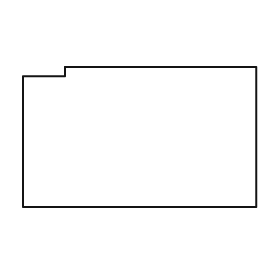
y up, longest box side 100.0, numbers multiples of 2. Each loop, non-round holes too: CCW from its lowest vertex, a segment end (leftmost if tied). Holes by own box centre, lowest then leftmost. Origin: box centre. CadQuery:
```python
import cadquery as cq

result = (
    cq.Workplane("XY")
    .moveTo(-50.0, -30.0)
    .lineTo(50.0, -30.0)
    .lineTo(50.0, 30.0)
    .lineTo(-32.0, 30.0)
    .lineTo(-32.0, 26.0)
    .lineTo(-50.0, 26.0)
    .close()
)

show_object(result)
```